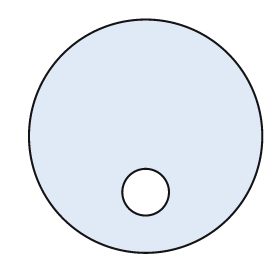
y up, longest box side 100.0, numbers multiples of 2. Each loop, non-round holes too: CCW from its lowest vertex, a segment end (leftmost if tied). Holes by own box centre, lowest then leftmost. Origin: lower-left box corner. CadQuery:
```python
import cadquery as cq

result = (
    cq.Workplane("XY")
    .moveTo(50.0, 50.0)
    .circle(50.0)
    .moveTo(50.0, 26.0)
    .circle(10.0)
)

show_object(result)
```